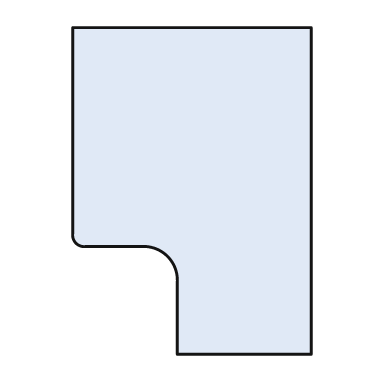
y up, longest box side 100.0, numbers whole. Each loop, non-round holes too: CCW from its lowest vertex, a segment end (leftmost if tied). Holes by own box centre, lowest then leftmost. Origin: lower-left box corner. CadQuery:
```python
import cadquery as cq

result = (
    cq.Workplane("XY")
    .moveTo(32.0, 0.0)
    .lineTo(73.0, 0.0)
    .lineTo(73.0, 100.0)
    .lineTo(0.0, 100.0)
    .lineTo(0.0, 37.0)
    .threePointArc((1.0, 34.0), (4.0, 33.0))
    .lineTo(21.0, 33.0)
    .threePointArc((29.0, 30.0), (32.0, 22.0))
    .close()
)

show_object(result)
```